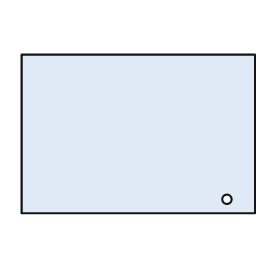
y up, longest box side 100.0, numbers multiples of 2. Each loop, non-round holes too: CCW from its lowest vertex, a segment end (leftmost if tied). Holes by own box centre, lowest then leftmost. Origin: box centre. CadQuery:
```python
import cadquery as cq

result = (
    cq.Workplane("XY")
    .moveTo(-50.0, -34.0)
    .lineTo(50.0, -34.0)
    .lineTo(50.0, 34.0)
    .lineTo(-50.0, 34.0)
    .close()
    .moveTo(38.0, -28.0)
    .circle(2.0)
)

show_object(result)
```